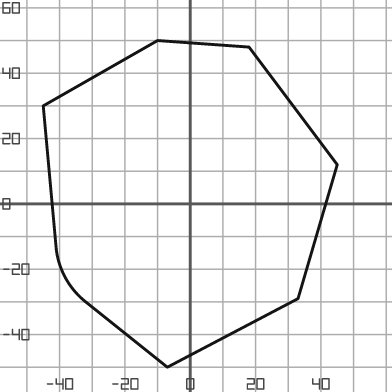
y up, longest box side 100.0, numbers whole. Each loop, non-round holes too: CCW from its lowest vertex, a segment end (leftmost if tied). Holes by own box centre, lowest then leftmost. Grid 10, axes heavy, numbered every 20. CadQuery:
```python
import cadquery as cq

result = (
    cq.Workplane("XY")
    .moveTo(-7.0, -50.0)
    .lineTo(33.0, -29.0)
    .lineTo(45.0, 12.0)
    .lineTo(18.0, 48.0)
    .lineTo(-10.0, 50.0)
    .lineTo(-45.0, 30.0)
    .lineTo(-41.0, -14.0)
    .threePointArc((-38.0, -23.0), (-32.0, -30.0))
    .close()
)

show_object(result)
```